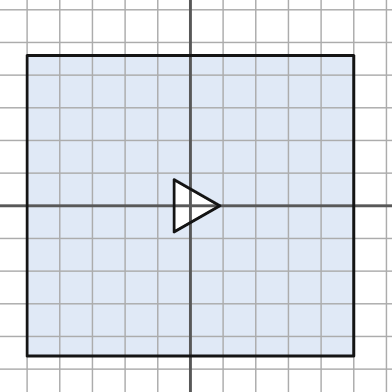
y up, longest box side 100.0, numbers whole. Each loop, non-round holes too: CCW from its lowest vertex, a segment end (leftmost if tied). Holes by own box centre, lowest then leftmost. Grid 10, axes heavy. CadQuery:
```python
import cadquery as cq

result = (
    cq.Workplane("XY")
    .moveTo(-50.0, -46.0)
    .lineTo(50.0, -46.0)
    .lineTo(50.0, 46.0)
    .lineTo(-50.0, 46.0)
    .close()
    .moveTo(-5.0, -8.0)
    .lineTo(9.0, 0.0)
    .lineTo(-5.0, 8.0)
    .close()
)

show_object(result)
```